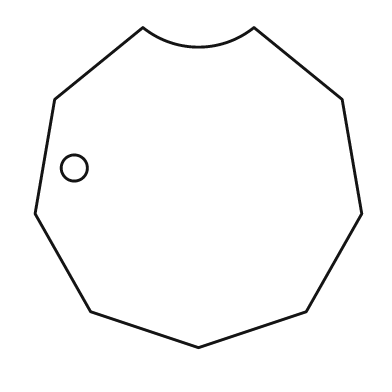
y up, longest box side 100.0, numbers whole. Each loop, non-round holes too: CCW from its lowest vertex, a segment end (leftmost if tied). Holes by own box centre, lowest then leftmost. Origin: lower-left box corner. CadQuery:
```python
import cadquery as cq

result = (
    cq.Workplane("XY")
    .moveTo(50.0, 0.0)
    .lineTo(83.0, 11.0)
    .lineTo(100.0, 41.0)
    .lineTo(94.0, 76.0)
    .lineTo(67.0, 98.0)
    .threePointArc((50.0, 92.0), (33.0, 98.0))
    .lineTo(6.0, 76.0)
    .lineTo(0.0, 41.0)
    .lineTo(17.0, 11.0)
    .close()
    .moveTo(12.0, 55.0)
    .circle(4.0)
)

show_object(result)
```